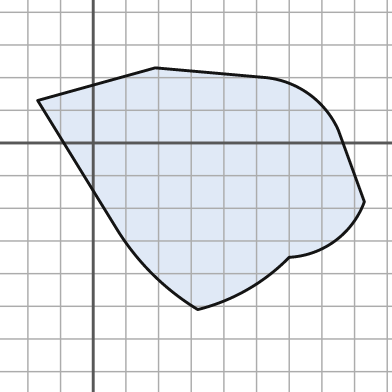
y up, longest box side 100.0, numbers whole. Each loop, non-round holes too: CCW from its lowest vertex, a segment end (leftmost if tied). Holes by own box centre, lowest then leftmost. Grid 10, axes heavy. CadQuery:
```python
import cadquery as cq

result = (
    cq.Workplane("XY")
    .moveTo(32.0, -51.0)
    .threePointArc((47.0, -45.0), (60.0, -35.0))
    .threePointArc((74.0, -30.0), (83.0, -18.0))
    .lineTo(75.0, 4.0)
    .threePointArc((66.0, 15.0), (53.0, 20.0))
    .lineTo(19.0, 23.0)
    .lineTo(-17.0, 13.0)
    .lineTo(7.0, -26.0)
    .threePointArc((18.0, -40.0), (32.0, -51.0))
    .close()
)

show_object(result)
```